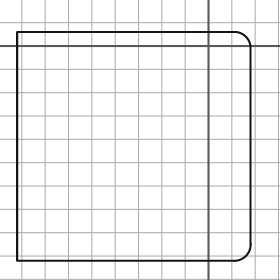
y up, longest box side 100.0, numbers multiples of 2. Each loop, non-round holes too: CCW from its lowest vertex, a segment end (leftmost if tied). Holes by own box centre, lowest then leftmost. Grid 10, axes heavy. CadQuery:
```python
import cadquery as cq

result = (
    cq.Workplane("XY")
    .moveTo(-82.0, -92.0)
    .lineTo(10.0, -92.0)
    .threePointArc((16.0, -90.0), (18.0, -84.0))
    .lineTo(18.0, 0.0)
    .threePointArc((16.0, 4.0), (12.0, 6.0))
    .lineTo(-82.0, 6.0)
    .close()
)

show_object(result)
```